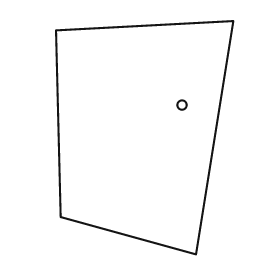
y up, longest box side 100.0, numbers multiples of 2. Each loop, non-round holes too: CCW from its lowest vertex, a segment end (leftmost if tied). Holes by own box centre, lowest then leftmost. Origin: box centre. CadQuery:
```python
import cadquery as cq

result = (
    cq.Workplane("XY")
    .moveTo(22.0, -50.0)
    .lineTo(38.0, 50.0)
    .lineTo(-38.0, 46.0)
    .lineTo(-36.0, -34.0)
    .close()
    .moveTo(16.0, 14.0)
    .circle(2.0)
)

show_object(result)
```